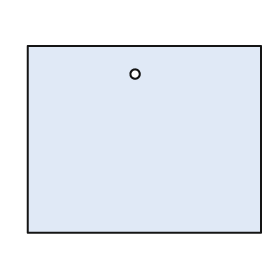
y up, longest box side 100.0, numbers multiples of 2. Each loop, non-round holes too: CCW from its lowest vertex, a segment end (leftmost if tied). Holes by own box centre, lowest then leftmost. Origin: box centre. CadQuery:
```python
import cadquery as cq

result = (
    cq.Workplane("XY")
    .moveTo(-50.0, -40.0)
    .lineTo(50.0, -40.0)
    .lineTo(50.0, 40.0)
    .lineTo(-50.0, 40.0)
    .close()
    .moveTo(-4.0, 28.0)
    .circle(2.0)
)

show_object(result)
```